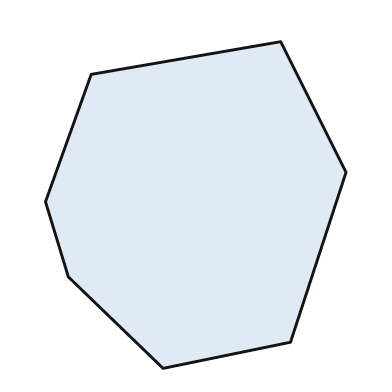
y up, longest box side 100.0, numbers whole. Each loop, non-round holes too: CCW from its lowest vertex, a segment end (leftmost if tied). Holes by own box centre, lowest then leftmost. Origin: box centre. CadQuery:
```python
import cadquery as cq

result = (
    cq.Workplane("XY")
    .moveTo(-10.0, -50.0)
    .lineTo(29.0, -42.0)
    .lineTo(46.0, 10.0)
    .lineTo(26.0, 50.0)
    .lineTo(-32.0, 40.0)
    .lineTo(-46.0, 1.0)
    .lineTo(-39.0, -22.0)
    .close()
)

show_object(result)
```